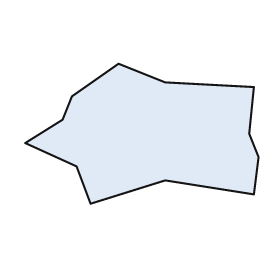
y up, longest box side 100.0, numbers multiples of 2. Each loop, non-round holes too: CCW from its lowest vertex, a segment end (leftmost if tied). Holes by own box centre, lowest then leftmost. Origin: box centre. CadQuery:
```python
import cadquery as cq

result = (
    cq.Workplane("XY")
    .moveTo(-22.0, -30.0)
    .lineTo(10.0, -20.0)
    .lineTo(48.0, -26.0)
    .lineTo(50.0, -10.0)
    .lineTo(46.0, 0.0)
    .lineTo(48.0, 20.0)
    .lineTo(10.0, 22.0)
    .lineTo(-10.0, 30.0)
    .lineTo(-30.0, 16.0)
    .lineTo(-34.0, 6.0)
    .lineTo(-50.0, -4.0)
    .lineTo(-28.0, -14.0)
    .close()
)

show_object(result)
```